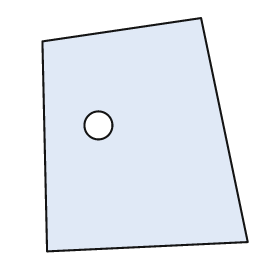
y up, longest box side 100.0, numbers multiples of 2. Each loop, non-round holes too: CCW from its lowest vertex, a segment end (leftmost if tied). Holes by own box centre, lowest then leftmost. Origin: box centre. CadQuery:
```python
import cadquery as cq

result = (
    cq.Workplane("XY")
    .moveTo(-42.0, -50.0)
    .lineTo(44.0, -46.0)
    .lineTo(24.0, 50.0)
    .lineTo(-44.0, 40.0)
    .close()
    .moveTo(-20.0, 4.0)
    .circle(6.0)
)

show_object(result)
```